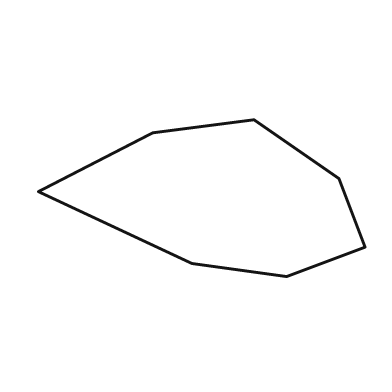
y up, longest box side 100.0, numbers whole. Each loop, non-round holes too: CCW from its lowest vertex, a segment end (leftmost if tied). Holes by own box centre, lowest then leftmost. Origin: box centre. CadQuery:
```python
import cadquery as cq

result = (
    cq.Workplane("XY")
    .moveTo(26.0, -24.0)
    .lineTo(50.0, -15.0)
    .lineTo(42.0, 6.0)
    .lineTo(16.0, 24.0)
    .lineTo(-15.0, 20.0)
    .lineTo(-50.0, 2.0)
    .lineTo(-3.0, -20.0)
    .close()
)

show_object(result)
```